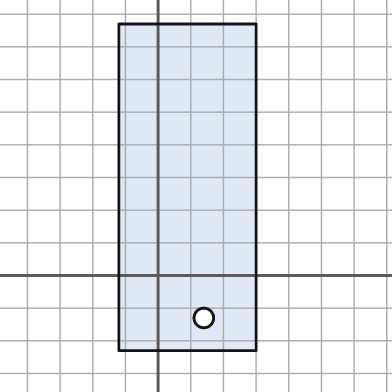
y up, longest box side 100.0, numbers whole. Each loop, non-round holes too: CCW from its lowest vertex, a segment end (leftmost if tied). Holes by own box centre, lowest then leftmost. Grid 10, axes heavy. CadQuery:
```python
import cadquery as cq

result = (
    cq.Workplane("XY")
    .moveTo(-12.0, -23.0)
    .lineTo(30.0, -23.0)
    .lineTo(30.0, 77.0)
    .lineTo(-12.0, 77.0)
    .close()
    .moveTo(14.0, -13.0)
    .circle(3.0)
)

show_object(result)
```